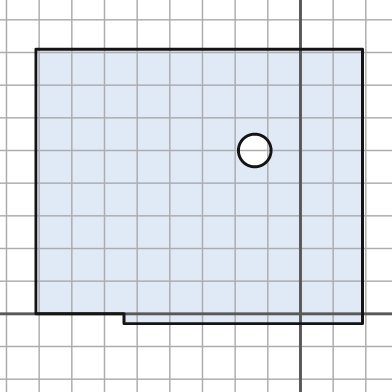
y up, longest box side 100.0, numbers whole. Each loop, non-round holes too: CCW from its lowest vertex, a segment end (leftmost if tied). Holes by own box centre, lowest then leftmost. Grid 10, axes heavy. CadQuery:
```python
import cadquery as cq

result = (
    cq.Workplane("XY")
    .moveTo(-54.0, -3.0)
    .lineTo(19.0, -3.0)
    .lineTo(19.0, 81.0)
    .lineTo(-81.0, 81.0)
    .lineTo(-81.0, 0.0)
    .lineTo(-54.0, 0.0)
    .close()
    .moveTo(-14.0, 50.0)
    .circle(5.0)
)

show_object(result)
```